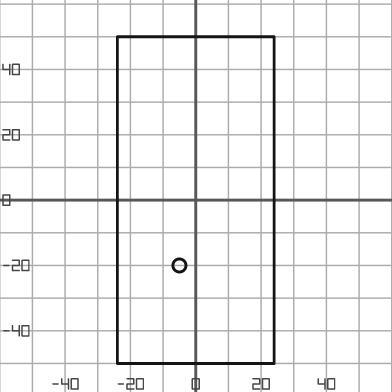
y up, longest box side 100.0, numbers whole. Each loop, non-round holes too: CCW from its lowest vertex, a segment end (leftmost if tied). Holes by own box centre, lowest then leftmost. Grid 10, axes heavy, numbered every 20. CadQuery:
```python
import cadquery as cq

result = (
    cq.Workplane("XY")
    .moveTo(-24.0, -50.0)
    .lineTo(24.0, -50.0)
    .lineTo(24.0, 50.0)
    .lineTo(-24.0, 50.0)
    .close()
    .moveTo(-5.0, -20.0)
    .circle(2.0)
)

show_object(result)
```